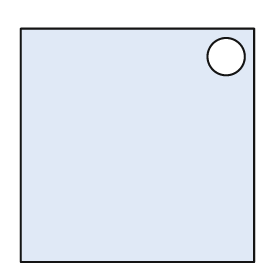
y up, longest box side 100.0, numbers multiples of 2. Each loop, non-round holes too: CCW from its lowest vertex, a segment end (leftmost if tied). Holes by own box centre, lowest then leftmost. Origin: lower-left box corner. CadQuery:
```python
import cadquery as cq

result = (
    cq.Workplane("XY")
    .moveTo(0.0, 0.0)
    .lineTo(100.0, 0.0)
    .lineTo(100.0, 100.0)
    .lineTo(0.0, 100.0)
    .close()
    .moveTo(88.0, 88.0)
    .circle(8.0)
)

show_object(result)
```